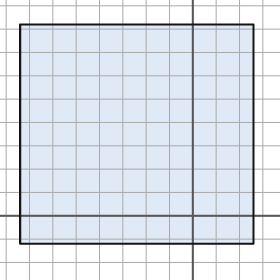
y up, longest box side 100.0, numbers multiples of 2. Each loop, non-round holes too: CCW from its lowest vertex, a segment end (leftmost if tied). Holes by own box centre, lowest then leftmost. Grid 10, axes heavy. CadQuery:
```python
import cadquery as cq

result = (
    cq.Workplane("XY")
    .moveTo(-74.0, -12.0)
    .lineTo(26.0, -12.0)
    .lineTo(26.0, 82.0)
    .lineTo(-74.0, 82.0)
    .close()
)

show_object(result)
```